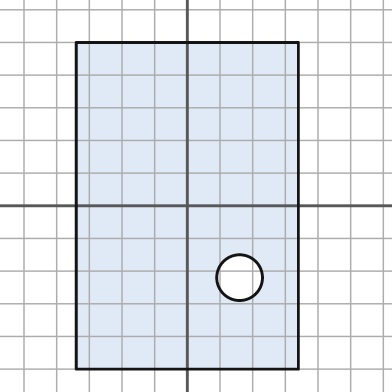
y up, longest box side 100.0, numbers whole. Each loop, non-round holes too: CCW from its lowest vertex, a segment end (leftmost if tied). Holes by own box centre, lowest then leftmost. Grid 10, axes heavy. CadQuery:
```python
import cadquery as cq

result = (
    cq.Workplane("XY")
    .moveTo(-34.0, -50.0)
    .lineTo(34.0, -50.0)
    .lineTo(34.0, 50.0)
    .lineTo(-34.0, 50.0)
    .close()
    .moveTo(16.0, -22.0)
    .circle(7.0)
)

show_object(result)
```